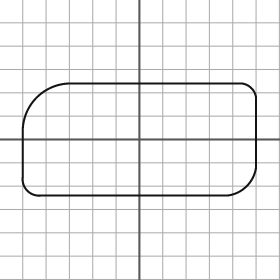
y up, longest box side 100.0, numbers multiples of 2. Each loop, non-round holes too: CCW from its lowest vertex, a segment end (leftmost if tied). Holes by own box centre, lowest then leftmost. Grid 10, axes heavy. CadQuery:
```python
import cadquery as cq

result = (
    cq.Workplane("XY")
    .moveTo(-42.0, -24.0)
    .lineTo(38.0, -24.0)
    .threePointArc((46.0, -20.0), (50.0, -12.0))
    .lineTo(50.0, 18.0)
    .threePointArc((48.0, 22.0), (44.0, 24.0))
    .lineTo(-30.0, 24.0)
    .threePointArc((-44.0, 18.0), (-50.0, 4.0))
    .lineTo(-50.0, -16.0)
    .threePointArc((-48.0, -22.0), (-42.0, -24.0))
    .close()
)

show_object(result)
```